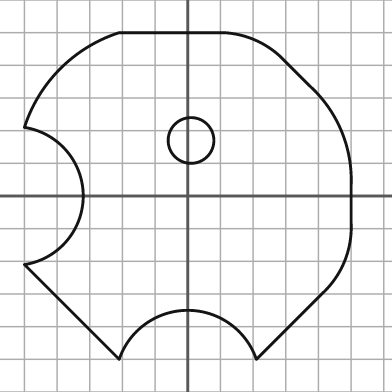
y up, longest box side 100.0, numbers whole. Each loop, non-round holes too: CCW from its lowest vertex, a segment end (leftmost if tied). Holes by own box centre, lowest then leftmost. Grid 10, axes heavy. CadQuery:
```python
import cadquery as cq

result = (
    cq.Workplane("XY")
    .moveTo(-21.0, -50.0)
    .threePointArc((0.0, -35.0), (21.0, -50.0))
    .lineTo(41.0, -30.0)
    .threePointArc((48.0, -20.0), (50.0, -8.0))
    .lineTo(50.0, 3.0)
    .threePointArc((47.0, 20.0), (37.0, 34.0))
    .lineTo(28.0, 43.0)
    .threePointArc((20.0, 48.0), (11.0, 50.0))
    .lineTo(-21.0, 50.0)
    .threePointArc((-39.0, 39.0), (-50.0, 21.0))
    .threePointArc((-32.0, 0.0), (-50.0, -21.0))
    .close()
    .moveTo(1.0, 17.0)
    .circle(7.0)
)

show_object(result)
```